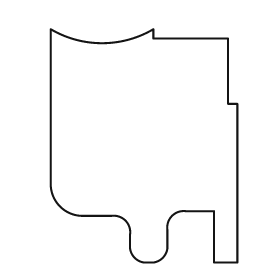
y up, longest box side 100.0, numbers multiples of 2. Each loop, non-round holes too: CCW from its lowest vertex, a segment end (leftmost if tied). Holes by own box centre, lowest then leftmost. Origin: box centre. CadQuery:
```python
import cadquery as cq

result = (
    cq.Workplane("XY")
    .moveTo(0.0, -50.0)
    .lineTo(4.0, -50.0)
    .threePointArc((8.0, -48.0), (10.0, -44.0))
    .lineTo(10.0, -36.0)
    .threePointArc((12.0, -30.0), (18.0, -28.0))
    .lineTo(30.0, -28.0)
    .lineTo(30.0, -50.0)
    .lineTo(40.0, -50.0)
    .lineTo(40.0, 18.0)
    .lineTo(36.0, 18.0)
    .lineTo(36.0, 46.0)
    .lineTo(4.0, 46.0)
    .lineTo(4.0, 50.0)
    .threePointArc((-18.0, 44.0), (-40.0, 50.0))
    .lineTo(-40.0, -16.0)
    .threePointArc((-36.0, -26.0), (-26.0, -30.0))
    .lineTo(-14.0, -30.0)
    .threePointArc((-8.0, -32.0), (-6.0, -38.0))
    .lineTo(-6.0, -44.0)
    .threePointArc((-4.0, -48.0), (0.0, -50.0))
    .close()
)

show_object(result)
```